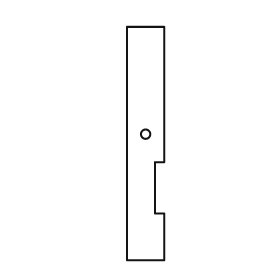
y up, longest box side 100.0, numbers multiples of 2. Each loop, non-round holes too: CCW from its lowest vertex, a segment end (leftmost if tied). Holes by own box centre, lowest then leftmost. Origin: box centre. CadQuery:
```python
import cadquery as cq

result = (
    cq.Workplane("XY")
    .moveTo(-8.0, -50.0)
    .lineTo(8.0, -50.0)
    .lineTo(8.0, -30.0)
    .lineTo(4.0, -30.0)
    .lineTo(4.0, -8.0)
    .lineTo(8.0, -8.0)
    .lineTo(8.0, 50.0)
    .lineTo(-8.0, 50.0)
    .close()
    .moveTo(0.0, 4.0)
    .circle(2.0)
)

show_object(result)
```